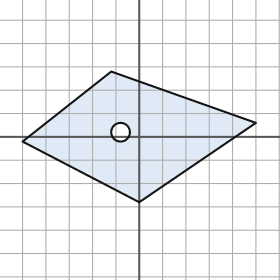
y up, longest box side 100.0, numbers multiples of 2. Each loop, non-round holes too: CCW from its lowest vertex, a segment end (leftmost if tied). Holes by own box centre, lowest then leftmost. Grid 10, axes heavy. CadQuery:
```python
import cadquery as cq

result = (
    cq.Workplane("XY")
    .moveTo(0.0, -28.0)
    .lineTo(50.0, 6.0)
    .lineTo(-12.0, 28.0)
    .lineTo(-50.0, -2.0)
    .close()
    .moveTo(-8.0, 2.0)
    .circle(4.0)
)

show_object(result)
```